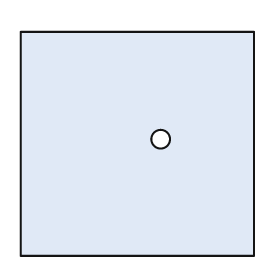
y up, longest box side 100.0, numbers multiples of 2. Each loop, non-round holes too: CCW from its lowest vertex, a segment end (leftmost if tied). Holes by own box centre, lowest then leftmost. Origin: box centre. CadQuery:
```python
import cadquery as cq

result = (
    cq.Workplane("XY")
    .moveTo(-50.0, -48.0)
    .lineTo(50.0, -48.0)
    .lineTo(50.0, 48.0)
    .lineTo(-50.0, 48.0)
    .close()
    .moveTo(10.0, 2.0)
    .circle(4.0)
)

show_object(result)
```